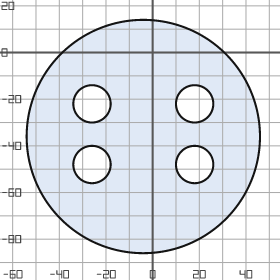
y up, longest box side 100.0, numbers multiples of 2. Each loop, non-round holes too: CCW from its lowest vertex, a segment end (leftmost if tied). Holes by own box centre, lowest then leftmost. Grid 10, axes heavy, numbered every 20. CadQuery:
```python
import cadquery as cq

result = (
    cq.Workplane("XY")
    .moveTo(-4.0, -36.0)
    .circle(50.0)
    .moveTo(-26.0, -48.0)
    .circle(8.0)
    .moveTo(18.0, -48.0)
    .circle(8.0)
    .moveTo(-26.0, -22.0)
    .circle(8.0)
    .moveTo(18.0, -22.0)
    .circle(8.0)
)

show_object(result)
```